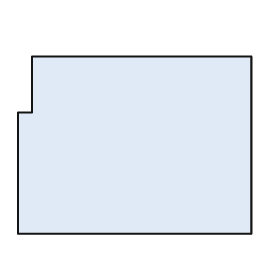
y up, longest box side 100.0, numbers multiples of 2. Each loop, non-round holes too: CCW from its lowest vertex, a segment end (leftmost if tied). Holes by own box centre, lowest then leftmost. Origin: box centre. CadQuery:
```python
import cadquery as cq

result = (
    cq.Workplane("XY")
    .moveTo(-50.0, -38.0)
    .lineTo(50.0, -38.0)
    .lineTo(50.0, 38.0)
    .lineTo(-44.0, 38.0)
    .lineTo(-44.0, 14.0)
    .lineTo(-50.0, 14.0)
    .close()
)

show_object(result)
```